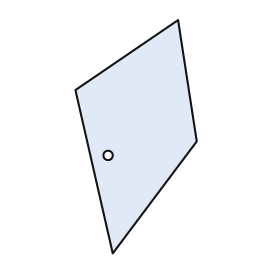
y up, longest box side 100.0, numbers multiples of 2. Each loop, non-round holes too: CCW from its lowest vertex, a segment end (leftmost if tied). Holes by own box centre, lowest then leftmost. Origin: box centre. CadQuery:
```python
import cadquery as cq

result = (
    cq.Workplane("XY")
    .moveTo(-10.0, -50.0)
    .lineTo(26.0, -2.0)
    .lineTo(18.0, 50.0)
    .lineTo(-26.0, 20.0)
    .close()
    .moveTo(-12.0, -8.0)
    .circle(2.0)
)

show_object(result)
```